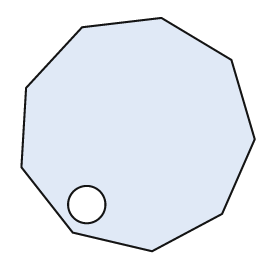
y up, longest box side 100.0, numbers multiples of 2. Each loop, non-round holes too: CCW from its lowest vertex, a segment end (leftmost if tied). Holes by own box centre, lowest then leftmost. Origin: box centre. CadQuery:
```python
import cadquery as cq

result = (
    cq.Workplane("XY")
    .moveTo(6.0, -50.0)
    .lineTo(36.0, -34.0)
    .lineTo(50.0, -2.0)
    .lineTo(40.0, 32.0)
    .lineTo(10.0, 50.0)
    .lineTo(-24.0, 46.0)
    .lineTo(-48.0, 20.0)
    .lineTo(-50.0, -14.0)
    .lineTo(-28.0, -42.0)
    .close()
    .moveTo(-22.0, -30.0)
    .circle(8.0)
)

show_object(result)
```